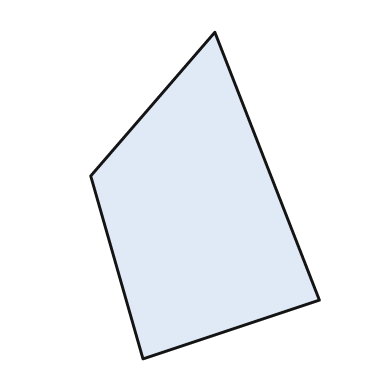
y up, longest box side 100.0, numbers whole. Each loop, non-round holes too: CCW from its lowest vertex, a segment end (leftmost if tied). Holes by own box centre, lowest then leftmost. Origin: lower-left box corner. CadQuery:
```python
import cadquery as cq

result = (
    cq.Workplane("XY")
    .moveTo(16.0, 0.0)
    .lineTo(70.0, 18.0)
    .lineTo(38.0, 100.0)
    .lineTo(0.0, 56.0)
    .close()
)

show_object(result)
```